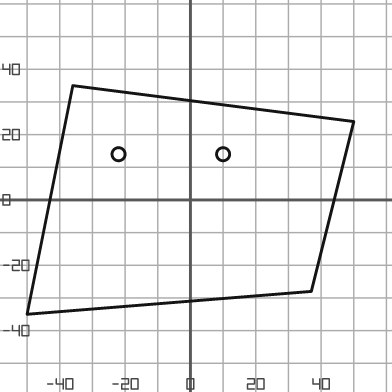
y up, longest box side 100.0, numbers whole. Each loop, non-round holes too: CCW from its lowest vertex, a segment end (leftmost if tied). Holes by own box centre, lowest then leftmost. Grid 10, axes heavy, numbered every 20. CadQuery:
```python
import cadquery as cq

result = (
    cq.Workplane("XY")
    .moveTo(-50.0, -35.0)
    .lineTo(37.0, -28.0)
    .lineTo(50.0, 24.0)
    .lineTo(-36.0, 35.0)
    .close()
    .moveTo(-22.0, 14.0)
    .circle(2.0)
    .moveTo(10.0, 14.0)
    .circle(2.0)
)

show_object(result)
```